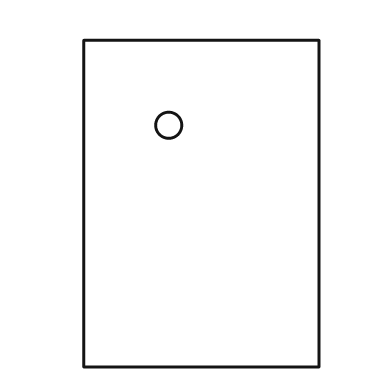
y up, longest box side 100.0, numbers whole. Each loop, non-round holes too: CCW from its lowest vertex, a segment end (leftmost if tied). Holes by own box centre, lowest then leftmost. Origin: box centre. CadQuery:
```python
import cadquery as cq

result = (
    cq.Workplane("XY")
    .moveTo(-36.0, -50.0)
    .lineTo(36.0, -50.0)
    .lineTo(36.0, 50.0)
    .lineTo(-36.0, 50.0)
    .close()
    .moveTo(-10.0, 24.0)
    .circle(4.0)
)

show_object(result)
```